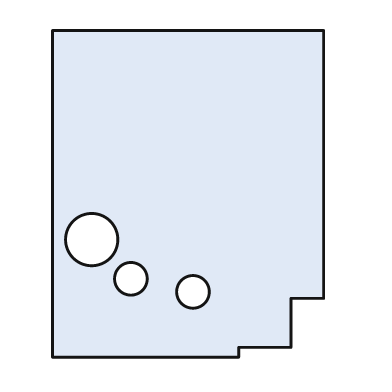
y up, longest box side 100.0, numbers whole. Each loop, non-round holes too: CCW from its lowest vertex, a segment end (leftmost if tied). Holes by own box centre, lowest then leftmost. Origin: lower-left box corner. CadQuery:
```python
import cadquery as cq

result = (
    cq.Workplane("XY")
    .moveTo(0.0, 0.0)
    .lineTo(57.0, 0.0)
    .lineTo(57.0, 3.0)
    .lineTo(73.0, 3.0)
    .lineTo(73.0, 18.0)
    .lineTo(83.0, 18.0)
    .lineTo(83.0, 100.0)
    .lineTo(0.0, 100.0)
    .close()
    .moveTo(43.0, 20.0)
    .circle(5.0)
    .moveTo(24.0, 24.0)
    .circle(5.0)
    .moveTo(12.0, 36.0)
    .circle(8.0)
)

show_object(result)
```